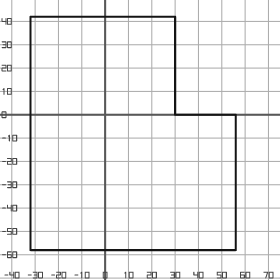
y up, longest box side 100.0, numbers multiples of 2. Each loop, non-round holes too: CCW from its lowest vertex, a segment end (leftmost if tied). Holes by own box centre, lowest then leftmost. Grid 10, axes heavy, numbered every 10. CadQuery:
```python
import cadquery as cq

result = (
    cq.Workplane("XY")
    .moveTo(-32.0, -58.0)
    .lineTo(56.0, -58.0)
    .lineTo(56.0, 0.0)
    .lineTo(30.0, 0.0)
    .lineTo(30.0, 42.0)
    .lineTo(-32.0, 42.0)
    .close()
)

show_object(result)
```